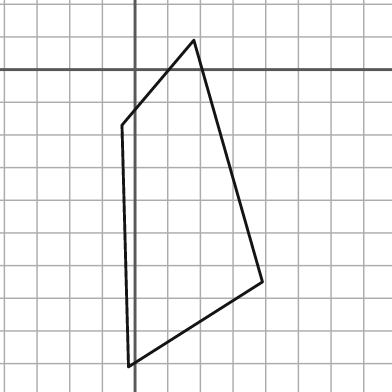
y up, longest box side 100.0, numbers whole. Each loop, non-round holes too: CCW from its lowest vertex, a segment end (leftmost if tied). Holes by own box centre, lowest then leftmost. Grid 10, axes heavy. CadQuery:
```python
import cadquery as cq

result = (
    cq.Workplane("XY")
    .moveTo(-2.0, -91.0)
    .lineTo(39.0, -65.0)
    .lineTo(18.0, 9.0)
    .lineTo(-4.0, -17.0)
    .close()
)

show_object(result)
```